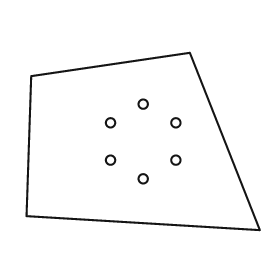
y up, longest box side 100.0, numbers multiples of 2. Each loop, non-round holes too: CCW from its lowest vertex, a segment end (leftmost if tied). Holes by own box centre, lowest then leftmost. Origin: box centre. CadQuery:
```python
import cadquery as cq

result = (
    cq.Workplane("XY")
    .moveTo(50.0, -38.0)
    .lineTo(20.0, 38.0)
    .lineTo(-48.0, 28.0)
    .lineTo(-50.0, -32.0)
    .close()
    .moveTo(0.0, -16.0)
    .circle(2.0)
    .moveTo(-14.0, -8.0)
    .circle(2.0)
    .moveTo(14.0, -8.0)
    .circle(2.0)
    .moveTo(-14.0, 8.0)
    .circle(2.0)
    .moveTo(14.0, 8.0)
    .circle(2.0)
    .moveTo(0.0, 16.0)
    .circle(2.0)
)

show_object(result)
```